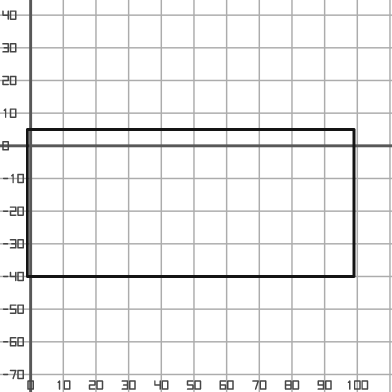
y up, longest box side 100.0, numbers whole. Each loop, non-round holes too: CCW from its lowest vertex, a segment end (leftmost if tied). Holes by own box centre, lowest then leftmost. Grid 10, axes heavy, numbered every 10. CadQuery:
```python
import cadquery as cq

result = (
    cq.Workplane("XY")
    .moveTo(-1.0, -40.0)
    .lineTo(99.0, -40.0)
    .lineTo(99.0, 5.0)
    .lineTo(-1.0, 5.0)
    .close()
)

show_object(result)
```